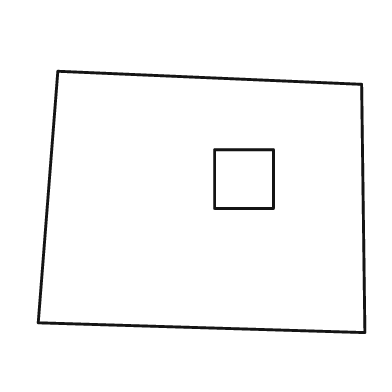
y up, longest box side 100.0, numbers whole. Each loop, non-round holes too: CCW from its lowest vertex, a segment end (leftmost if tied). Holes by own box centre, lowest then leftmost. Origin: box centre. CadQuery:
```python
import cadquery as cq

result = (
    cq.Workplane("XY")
    .moveTo(50.0, -40.0)
    .lineTo(49.0, 36.0)
    .lineTo(-44.0, 40.0)
    .lineTo(-50.0, -37.0)
    .close()
    .moveTo(4.0, -2.0)
    .lineTo(22.0, -2.0)
    .lineTo(22.0, 16.0)
    .lineTo(4.0, 16.0)
    .close()
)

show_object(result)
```